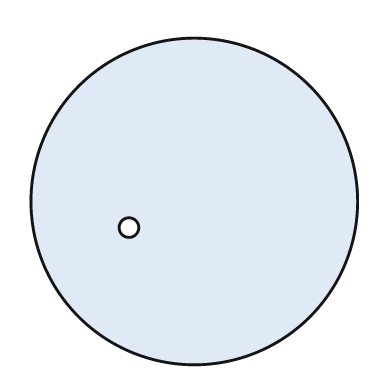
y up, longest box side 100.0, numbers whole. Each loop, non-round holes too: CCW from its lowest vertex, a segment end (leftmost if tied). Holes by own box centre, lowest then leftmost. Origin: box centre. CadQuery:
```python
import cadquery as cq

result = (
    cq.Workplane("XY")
    .moveTo(0.0, 0.0)
    .circle(50.0)
    .moveTo(-20.0, -8.0)
    .circle(3.0)
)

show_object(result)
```